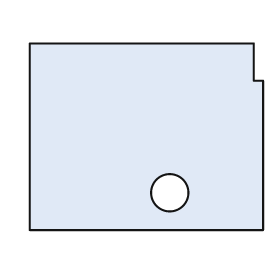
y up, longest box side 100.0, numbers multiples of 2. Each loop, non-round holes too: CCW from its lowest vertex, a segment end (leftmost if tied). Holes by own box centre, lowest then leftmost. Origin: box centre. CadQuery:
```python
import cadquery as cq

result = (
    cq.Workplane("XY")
    .moveTo(-50.0, -40.0)
    .lineTo(50.0, -40.0)
    .lineTo(50.0, 24.0)
    .lineTo(46.0, 24.0)
    .lineTo(46.0, 40.0)
    .lineTo(-50.0, 40.0)
    .close()
    .moveTo(10.0, -24.0)
    .circle(8.0)
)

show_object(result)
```